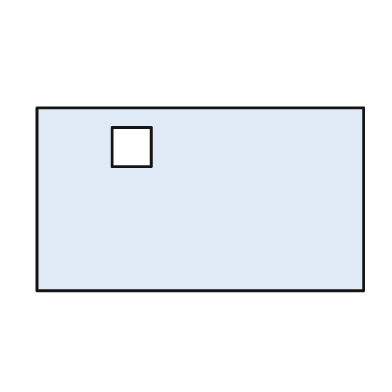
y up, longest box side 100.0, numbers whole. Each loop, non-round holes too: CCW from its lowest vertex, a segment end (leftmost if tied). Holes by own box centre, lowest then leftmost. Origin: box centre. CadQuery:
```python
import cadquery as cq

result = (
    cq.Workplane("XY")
    .moveTo(-50.0, -28.0)
    .lineTo(50.0, -28.0)
    .lineTo(50.0, 28.0)
    .lineTo(-50.0, 28.0)
    .close()
    .moveTo(-27.0, 10.0)
    .lineTo(-15.0, 10.0)
    .lineTo(-15.0, 22.0)
    .lineTo(-27.0, 22.0)
    .close()
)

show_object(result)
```